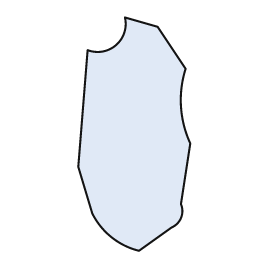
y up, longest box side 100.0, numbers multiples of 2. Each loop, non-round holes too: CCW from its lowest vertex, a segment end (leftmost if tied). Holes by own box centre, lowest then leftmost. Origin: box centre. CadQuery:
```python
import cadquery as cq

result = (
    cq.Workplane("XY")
    .moveTo(2.0, -50.0)
    .lineTo(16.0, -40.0)
    .threePointArc((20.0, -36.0), (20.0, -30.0))
    .lineTo(24.0, -4.0)
    .threePointArc((20.0, 12.0), (22.0, 28.0))
    .lineTo(10.0, 46.0)
    .lineTo(-4.0, 50.0)
    .threePointArc((-8.0, 38.0), (-20.0, 36.0))
    .lineTo(-24.0, -14.0)
    .lineTo(-18.0, -34.0)
    .threePointArc((-10.0, -44.0), (2.0, -50.0))
    .close()
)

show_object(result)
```